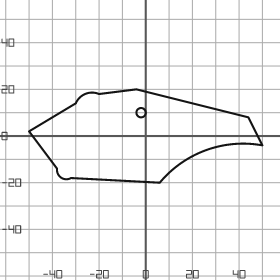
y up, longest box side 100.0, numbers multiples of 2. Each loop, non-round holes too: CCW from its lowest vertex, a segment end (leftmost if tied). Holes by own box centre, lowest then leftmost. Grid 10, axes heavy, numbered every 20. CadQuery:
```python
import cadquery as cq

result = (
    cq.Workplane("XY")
    .moveTo(6.0, -20.0)
    .threePointArc((26.0, -6.0), (50.0, -4.0))
    .lineTo(44.0, 8.0)
    .lineTo(-4.0, 20.0)
    .lineTo(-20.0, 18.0)
    .threePointArc((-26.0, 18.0), (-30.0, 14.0))
    .lineTo(-50.0, 2.0)
    .lineTo(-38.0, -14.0)
    .threePointArc((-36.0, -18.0), (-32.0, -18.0))
    .close()
    .moveTo(-2.0, 10.0)
    .circle(2.0)
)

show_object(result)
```